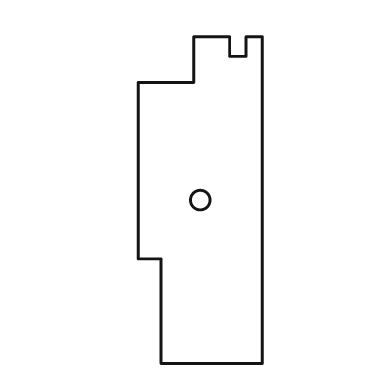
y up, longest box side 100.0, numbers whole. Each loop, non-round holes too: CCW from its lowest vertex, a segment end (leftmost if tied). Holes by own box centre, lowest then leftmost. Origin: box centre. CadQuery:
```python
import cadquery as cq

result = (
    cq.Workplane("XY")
    .moveTo(-12.0, -50.0)
    .lineTo(19.0, -50.0)
    .lineTo(19.0, 50.0)
    .lineTo(14.0, 50.0)
    .lineTo(14.0, 44.0)
    .lineTo(9.0, 44.0)
    .lineTo(9.0, 50.0)
    .lineTo(-2.0, 50.0)
    .lineTo(-2.0, 36.0)
    .lineTo(-19.0, 36.0)
    .lineTo(-19.0, -18.0)
    .lineTo(-12.0, -18.0)
    .close()
    .moveTo(0.0, 0.0)
    .circle(3.0)
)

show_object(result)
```